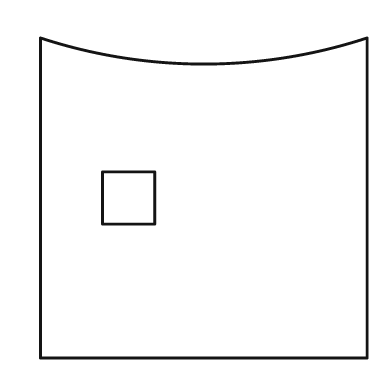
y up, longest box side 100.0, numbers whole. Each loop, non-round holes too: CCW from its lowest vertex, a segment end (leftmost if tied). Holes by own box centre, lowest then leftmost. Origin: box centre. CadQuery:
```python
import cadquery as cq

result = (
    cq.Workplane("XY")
    .moveTo(-50.0, -49.0)
    .lineTo(50.0, -49.0)
    .lineTo(50.0, 49.0)
    .threePointArc((0.0, 41.0), (-50.0, 49.0))
    .close()
    .moveTo(-31.0, -8.0)
    .lineTo(-15.0, -8.0)
    .lineTo(-15.0, 8.0)
    .lineTo(-31.0, 8.0)
    .close()
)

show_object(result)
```